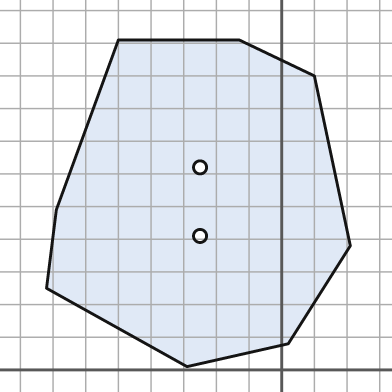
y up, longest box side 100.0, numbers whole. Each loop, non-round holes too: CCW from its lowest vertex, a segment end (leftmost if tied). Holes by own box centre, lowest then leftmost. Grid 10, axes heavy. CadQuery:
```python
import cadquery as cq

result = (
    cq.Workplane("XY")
    .moveTo(-29.0, 1.0)
    .lineTo(2.0, 8.0)
    .lineTo(21.0, 38.0)
    .lineTo(10.0, 90.0)
    .lineTo(-13.0, 101.0)
    .lineTo(-50.0, 101.0)
    .lineTo(-69.0, 49.0)
    .lineTo(-72.0, 25.0)
    .close()
    .moveTo(-25.0, 41.0)
    .circle(2.0)
    .moveTo(-25.0, 62.0)
    .circle(2.0)
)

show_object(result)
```